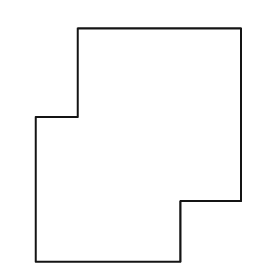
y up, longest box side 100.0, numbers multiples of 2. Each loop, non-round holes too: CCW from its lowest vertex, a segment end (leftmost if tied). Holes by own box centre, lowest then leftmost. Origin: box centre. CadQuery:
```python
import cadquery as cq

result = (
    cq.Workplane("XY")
    .moveTo(-44.0, -50.0)
    .lineTo(18.0, -50.0)
    .lineTo(18.0, -24.0)
    .lineTo(44.0, -24.0)
    .lineTo(44.0, 50.0)
    .lineTo(-26.0, 50.0)
    .lineTo(-26.0, 12.0)
    .lineTo(-44.0, 12.0)
    .close()
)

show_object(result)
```